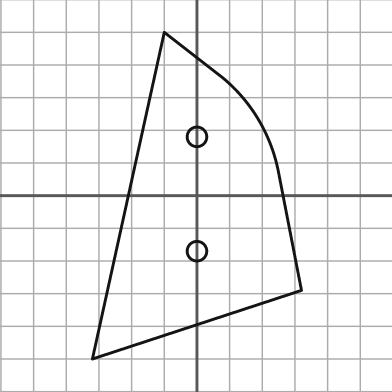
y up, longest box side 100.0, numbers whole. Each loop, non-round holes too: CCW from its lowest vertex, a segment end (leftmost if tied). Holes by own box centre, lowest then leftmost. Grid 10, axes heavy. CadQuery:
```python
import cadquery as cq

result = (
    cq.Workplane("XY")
    .moveTo(-32.0, -50.0)
    .lineTo(32.0, -29.0)
    .lineTo(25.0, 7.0)
    .threePointArc((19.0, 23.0), (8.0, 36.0))
    .lineTo(-10.0, 50.0)
    .close()
    .moveTo(0.0, -17.0)
    .circle(3.0)
    .moveTo(0.0, 18.0)
    .circle(3.0)
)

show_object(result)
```